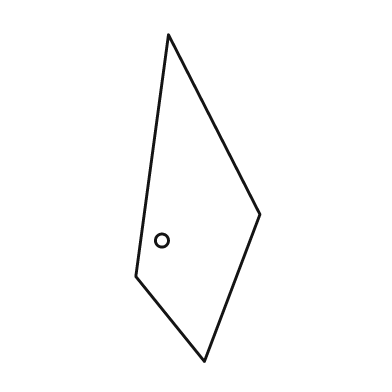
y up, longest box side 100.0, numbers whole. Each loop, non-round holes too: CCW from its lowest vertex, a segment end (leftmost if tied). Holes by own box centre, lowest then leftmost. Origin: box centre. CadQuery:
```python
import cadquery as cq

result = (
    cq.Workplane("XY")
    .moveTo(2.0, -50.0)
    .lineTo(19.0, -5.0)
    .lineTo(-9.0, 50.0)
    .lineTo(-19.0, -24.0)
    .close()
    .moveTo(-11.0, -13.0)
    .circle(2.0)
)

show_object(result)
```